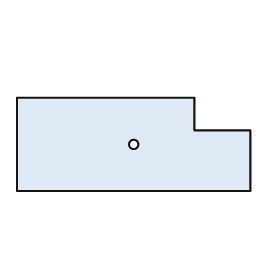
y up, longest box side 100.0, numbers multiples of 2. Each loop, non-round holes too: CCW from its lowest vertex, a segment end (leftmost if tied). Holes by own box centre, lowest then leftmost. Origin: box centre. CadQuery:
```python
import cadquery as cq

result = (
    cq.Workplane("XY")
    .moveTo(-50.0, -20.0)
    .lineTo(50.0, -20.0)
    .lineTo(50.0, 6.0)
    .lineTo(26.0, 6.0)
    .lineTo(26.0, 20.0)
    .lineTo(-50.0, 20.0)
    .close()
    .moveTo(0.0, 0.0)
    .circle(2.0)
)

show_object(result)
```